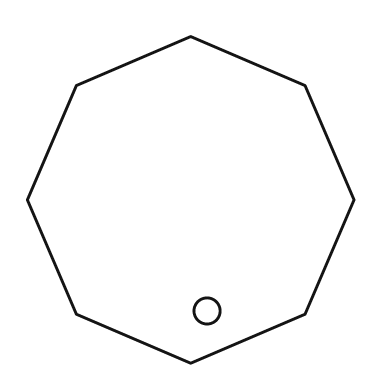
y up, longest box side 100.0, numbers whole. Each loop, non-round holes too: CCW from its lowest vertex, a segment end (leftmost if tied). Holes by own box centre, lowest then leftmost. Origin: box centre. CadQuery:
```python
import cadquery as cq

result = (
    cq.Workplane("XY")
    .moveTo(0.0, -50.0)
    .lineTo(35.0, -35.0)
    .lineTo(50.0, 0.0)
    .lineTo(35.0, 35.0)
    .lineTo(0.0, 50.0)
    .lineTo(-35.0, 35.0)
    .lineTo(-50.0, 0.0)
    .lineTo(-35.0, -35.0)
    .close()
    .moveTo(5.0, -34.0)
    .circle(4.0)
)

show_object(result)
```